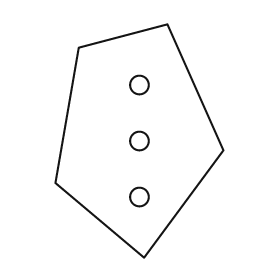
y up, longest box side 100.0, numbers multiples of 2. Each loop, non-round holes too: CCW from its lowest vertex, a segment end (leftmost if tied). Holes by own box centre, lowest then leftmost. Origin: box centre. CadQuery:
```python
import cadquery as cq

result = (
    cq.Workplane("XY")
    .moveTo(2.0, -50.0)
    .lineTo(36.0, -4.0)
    .lineTo(12.0, 50.0)
    .lineTo(-26.0, 40.0)
    .lineTo(-36.0, -18.0)
    .close()
    .moveTo(0.0, -24.0)
    .circle(4.0)
    .moveTo(0.0, 0.0)
    .circle(4.0)
    .moveTo(0.0, 24.0)
    .circle(4.0)
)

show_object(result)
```